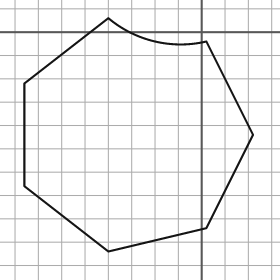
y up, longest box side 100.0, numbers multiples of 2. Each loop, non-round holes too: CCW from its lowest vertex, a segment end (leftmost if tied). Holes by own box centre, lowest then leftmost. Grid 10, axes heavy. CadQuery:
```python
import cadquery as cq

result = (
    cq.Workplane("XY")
    .moveTo(-40.0, -94.0)
    .lineTo(2.0, -84.0)
    .lineTo(22.0, -44.0)
    .lineTo(2.0, -4.0)
    .threePointArc((-20.0, -4.0), (-40.0, 6.0))
    .lineTo(-76.0, -22.0)
    .lineTo(-76.0, -66.0)
    .close()
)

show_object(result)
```